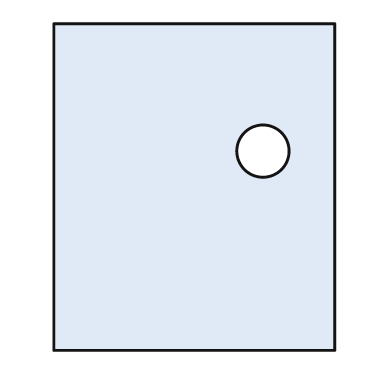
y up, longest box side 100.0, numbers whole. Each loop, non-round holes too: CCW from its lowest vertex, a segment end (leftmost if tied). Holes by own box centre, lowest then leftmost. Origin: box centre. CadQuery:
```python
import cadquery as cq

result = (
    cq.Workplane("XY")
    .moveTo(-43.0, -50.0)
    .lineTo(43.0, -50.0)
    .lineTo(43.0, 50.0)
    .lineTo(-43.0, 50.0)
    .close()
    .moveTo(21.0, 11.0)
    .circle(8.0)
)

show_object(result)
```